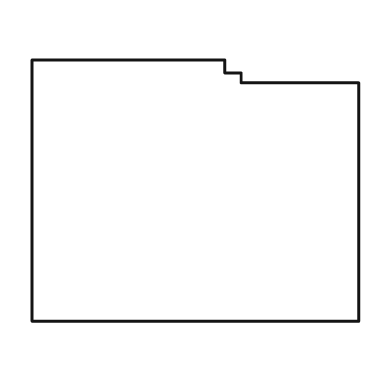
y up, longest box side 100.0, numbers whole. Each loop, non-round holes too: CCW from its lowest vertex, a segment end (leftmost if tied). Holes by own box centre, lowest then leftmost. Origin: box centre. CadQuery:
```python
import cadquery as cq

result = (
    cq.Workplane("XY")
    .moveTo(-50.0, -40.0)
    .lineTo(50.0, -40.0)
    .lineTo(50.0, 33.0)
    .lineTo(14.0, 33.0)
    .lineTo(14.0, 36.0)
    .lineTo(9.0, 36.0)
    .lineTo(9.0, 40.0)
    .lineTo(-50.0, 40.0)
    .close()
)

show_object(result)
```